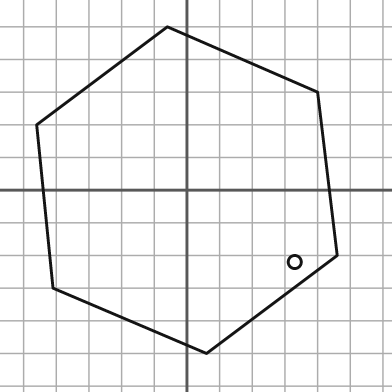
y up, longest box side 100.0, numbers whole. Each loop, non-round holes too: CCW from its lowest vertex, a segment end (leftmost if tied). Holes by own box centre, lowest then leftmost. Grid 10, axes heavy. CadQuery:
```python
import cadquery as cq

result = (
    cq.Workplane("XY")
    .moveTo(6.0, -50.0)
    .lineTo(46.0, -20.0)
    .lineTo(40.0, 30.0)
    .lineTo(-6.0, 50.0)
    .lineTo(-46.0, 20.0)
    .lineTo(-41.0, -30.0)
    .close()
    .moveTo(33.0, -22.0)
    .circle(2.0)
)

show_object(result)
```